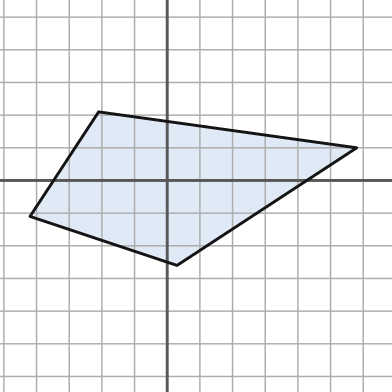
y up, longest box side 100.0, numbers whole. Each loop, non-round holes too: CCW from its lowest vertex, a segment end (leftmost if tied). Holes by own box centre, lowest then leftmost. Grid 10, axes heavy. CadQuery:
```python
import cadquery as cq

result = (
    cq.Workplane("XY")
    .moveTo(3.0, -26.0)
    .lineTo(58.0, 10.0)
    .lineTo(-21.0, 21.0)
    .lineTo(-42.0, -11.0)
    .close()
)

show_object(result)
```